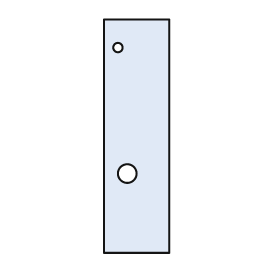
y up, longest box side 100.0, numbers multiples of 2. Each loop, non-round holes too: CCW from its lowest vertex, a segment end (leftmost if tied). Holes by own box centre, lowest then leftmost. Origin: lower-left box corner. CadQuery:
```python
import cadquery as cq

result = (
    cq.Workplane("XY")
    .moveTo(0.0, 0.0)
    .lineTo(28.0, 0.0)
    .lineTo(28.0, 100.0)
    .lineTo(0.0, 100.0)
    .close()
    .moveTo(10.0, 34.0)
    .circle(4.0)
    .moveTo(6.0, 88.0)
    .circle(2.0)
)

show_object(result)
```